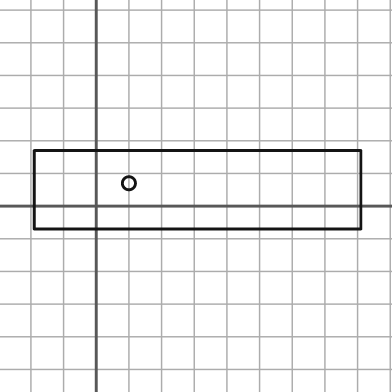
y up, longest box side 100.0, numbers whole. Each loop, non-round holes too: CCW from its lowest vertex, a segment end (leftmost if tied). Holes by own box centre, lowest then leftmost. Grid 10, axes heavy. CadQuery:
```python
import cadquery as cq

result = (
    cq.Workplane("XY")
    .moveTo(-19.0, -7.0)
    .lineTo(81.0, -7.0)
    .lineTo(81.0, 17.0)
    .lineTo(-19.0, 17.0)
    .close()
    .moveTo(10.0, 7.0)
    .circle(2.0)
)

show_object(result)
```